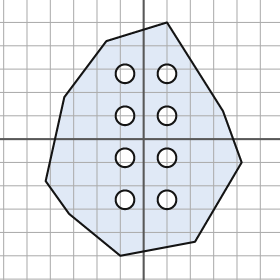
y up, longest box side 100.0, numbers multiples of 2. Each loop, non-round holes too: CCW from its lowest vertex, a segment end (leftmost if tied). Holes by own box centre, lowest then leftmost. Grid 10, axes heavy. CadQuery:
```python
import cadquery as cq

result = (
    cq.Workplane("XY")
    .moveTo(-10.0, -50.0)
    .lineTo(22.0, -44.0)
    .lineTo(42.0, -10.0)
    .lineTo(34.0, 12.0)
    .lineTo(10.0, 50.0)
    .lineTo(-16.0, 42.0)
    .lineTo(-34.0, 18.0)
    .lineTo(-42.0, -18.0)
    .lineTo(-32.0, -32.0)
    .close()
    .moveTo(-8.0, -26.0)
    .circle(4.0)
    .moveTo(10.0, -26.0)
    .circle(4.0)
    .moveTo(-8.0, -8.0)
    .circle(4.0)
    .moveTo(10.0, -8.0)
    .circle(4.0)
    .moveTo(-8.0, 10.0)
    .circle(4.0)
    .moveTo(10.0, 10.0)
    .circle(4.0)
    .moveTo(-8.0, 28.0)
    .circle(4.0)
    .moveTo(10.0, 28.0)
    .circle(4.0)
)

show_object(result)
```